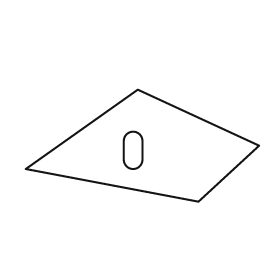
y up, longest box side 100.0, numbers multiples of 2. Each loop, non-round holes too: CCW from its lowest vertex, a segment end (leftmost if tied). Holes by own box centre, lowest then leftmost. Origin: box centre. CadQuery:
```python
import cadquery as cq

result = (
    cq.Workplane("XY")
    .moveTo(24.0, -24.0)
    .lineTo(50.0, 0.0)
    .lineTo(-2.0, 24.0)
    .lineTo(-50.0, -10.0)
    .close()
    .moveTo(-8.0, -6.0)
    .threePointArc((-4.0, -10.0), (0.0, -6.0))
    .lineTo(0.0, 2.0)
    .threePointArc((-4.0, 6.0), (-8.0, 2.0))
    .close()
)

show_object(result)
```